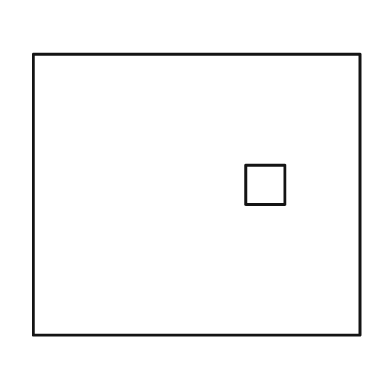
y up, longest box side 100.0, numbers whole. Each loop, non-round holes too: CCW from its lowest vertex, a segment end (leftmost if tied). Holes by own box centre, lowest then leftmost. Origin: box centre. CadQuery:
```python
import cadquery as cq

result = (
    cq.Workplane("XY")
    .moveTo(-50.0, -43.0)
    .lineTo(50.0, -43.0)
    .lineTo(50.0, 43.0)
    .lineTo(-50.0, 43.0)
    .close()
    .moveTo(15.0, -3.0)
    .lineTo(27.0, -3.0)
    .lineTo(27.0, 9.0)
    .lineTo(15.0, 9.0)
    .close()
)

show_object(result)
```